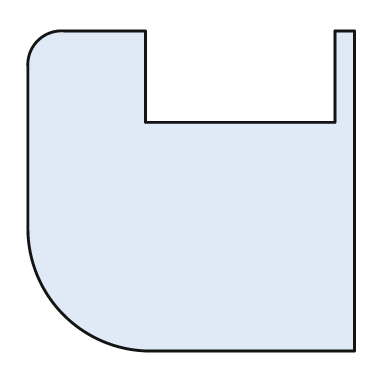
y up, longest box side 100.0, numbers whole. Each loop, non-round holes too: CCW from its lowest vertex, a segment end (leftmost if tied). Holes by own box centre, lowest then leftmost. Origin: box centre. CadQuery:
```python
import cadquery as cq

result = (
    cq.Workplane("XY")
    .moveTo(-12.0, -49.0)
    .lineTo(50.0, -49.0)
    .lineTo(50.0, 49.0)
    .lineTo(44.0, 49.0)
    .lineTo(44.0, 21.0)
    .lineTo(-14.0, 21.0)
    .lineTo(-14.0, 49.0)
    .lineTo(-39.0, 49.0)
    .threePointArc((-47.0, 46.0), (-50.0, 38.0))
    .lineTo(-50.0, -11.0)
    .threePointArc((-39.0, -38.0), (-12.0, -49.0))
    .close()
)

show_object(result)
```